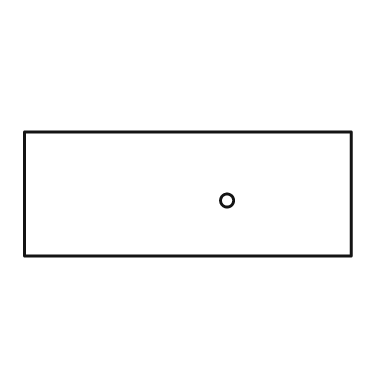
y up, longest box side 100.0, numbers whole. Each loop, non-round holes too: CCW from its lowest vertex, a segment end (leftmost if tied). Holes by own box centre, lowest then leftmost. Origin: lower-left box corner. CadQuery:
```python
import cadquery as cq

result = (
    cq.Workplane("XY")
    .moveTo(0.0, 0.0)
    .lineTo(100.0, 0.0)
    .lineTo(100.0, 38.0)
    .lineTo(0.0, 38.0)
    .close()
    .moveTo(62.0, 17.0)
    .circle(2.0)
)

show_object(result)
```